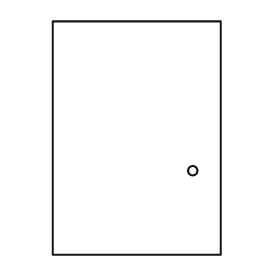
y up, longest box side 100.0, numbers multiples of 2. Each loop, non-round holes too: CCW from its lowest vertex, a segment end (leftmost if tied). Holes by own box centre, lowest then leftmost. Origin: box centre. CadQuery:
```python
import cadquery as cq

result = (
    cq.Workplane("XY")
    .moveTo(-36.0, -50.0)
    .lineTo(36.0, -50.0)
    .lineTo(36.0, 50.0)
    .lineTo(-36.0, 50.0)
    .close()
    .moveTo(24.0, -14.0)
    .circle(2.0)
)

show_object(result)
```